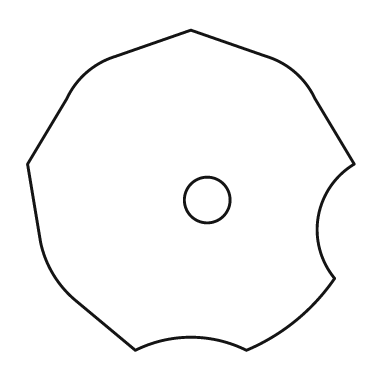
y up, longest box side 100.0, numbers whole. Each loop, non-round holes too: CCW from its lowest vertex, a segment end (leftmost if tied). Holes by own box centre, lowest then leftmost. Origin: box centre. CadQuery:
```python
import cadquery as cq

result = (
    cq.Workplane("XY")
    .moveTo(-17.0, -49.0)
    .threePointArc((0.0, -45.0), (17.0, -49.0))
    .threePointArc((32.0, -40.0), (44.0, -27.0))
    .threePointArc((39.0, -8.0), (50.0, 8.0))
    .lineTo(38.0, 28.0)
    .threePointArc((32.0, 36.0), (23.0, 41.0))
    .lineTo(0.0, 49.0)
    .lineTo(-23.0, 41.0)
    .threePointArc((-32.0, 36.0), (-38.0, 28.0))
    .lineTo(-50.0, 8.0)
    .lineTo(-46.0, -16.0)
    .threePointArc((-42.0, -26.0), (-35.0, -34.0))
    .close()
    .moveTo(5.0, -3.0)
    .circle(7.0)
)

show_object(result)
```